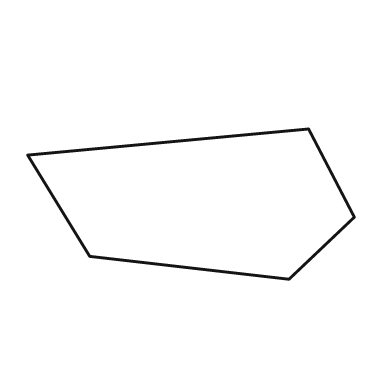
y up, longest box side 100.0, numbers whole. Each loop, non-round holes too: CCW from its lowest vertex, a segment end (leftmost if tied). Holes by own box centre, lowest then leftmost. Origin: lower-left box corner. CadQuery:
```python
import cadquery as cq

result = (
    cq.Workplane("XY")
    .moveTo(80.0, 0.0)
    .lineTo(100.0, 19.0)
    .lineTo(86.0, 46.0)
    .lineTo(0.0, 38.0)
    .lineTo(19.0, 7.0)
    .close()
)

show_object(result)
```